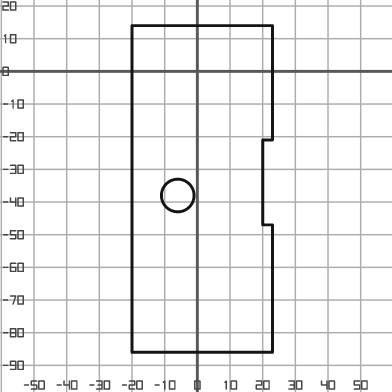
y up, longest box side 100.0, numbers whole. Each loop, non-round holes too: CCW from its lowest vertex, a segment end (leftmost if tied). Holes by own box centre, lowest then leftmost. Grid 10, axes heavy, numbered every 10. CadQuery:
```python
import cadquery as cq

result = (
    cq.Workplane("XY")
    .moveTo(-20.0, -86.0)
    .lineTo(23.0, -86.0)
    .lineTo(23.0, -47.0)
    .lineTo(20.0, -47.0)
    .lineTo(20.0, -21.0)
    .lineTo(23.0, -21.0)
    .lineTo(23.0, 14.0)
    .lineTo(-20.0, 14.0)
    .close()
    .moveTo(-6.0, -38.0)
    .circle(5.0)
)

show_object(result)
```